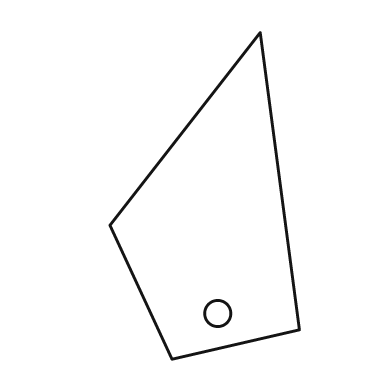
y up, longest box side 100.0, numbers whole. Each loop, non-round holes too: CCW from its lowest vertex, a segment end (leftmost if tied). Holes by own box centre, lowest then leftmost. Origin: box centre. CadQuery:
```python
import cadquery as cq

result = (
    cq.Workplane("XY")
    .moveTo(-10.0, -50.0)
    .lineTo(29.0, -41.0)
    .lineTo(17.0, 50.0)
    .lineTo(-29.0, -9.0)
    .close()
    .moveTo(4.0, -36.0)
    .circle(4.0)
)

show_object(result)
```